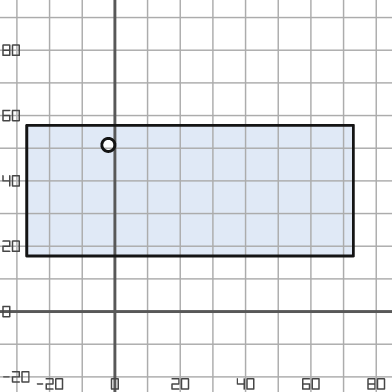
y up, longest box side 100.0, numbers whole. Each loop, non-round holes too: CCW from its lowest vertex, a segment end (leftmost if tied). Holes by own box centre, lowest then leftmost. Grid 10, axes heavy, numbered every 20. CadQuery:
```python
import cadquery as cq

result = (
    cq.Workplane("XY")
    .moveTo(-27.0, 17.0)
    .lineTo(73.0, 17.0)
    .lineTo(73.0, 57.0)
    .lineTo(-27.0, 57.0)
    .close()
    .moveTo(-2.0, 51.0)
    .circle(2.0)
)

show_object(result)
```